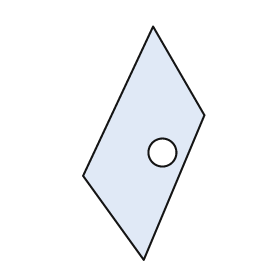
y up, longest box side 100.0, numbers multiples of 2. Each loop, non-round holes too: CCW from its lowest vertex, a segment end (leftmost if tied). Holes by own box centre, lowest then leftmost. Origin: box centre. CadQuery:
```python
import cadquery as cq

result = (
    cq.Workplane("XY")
    .moveTo(0.0, -50.0)
    .lineTo(26.0, 12.0)
    .lineTo(4.0, 50.0)
    .lineTo(-26.0, -14.0)
    .close()
    .moveTo(8.0, -4.0)
    .circle(6.0)
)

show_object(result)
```